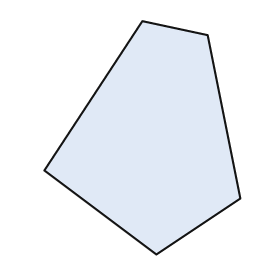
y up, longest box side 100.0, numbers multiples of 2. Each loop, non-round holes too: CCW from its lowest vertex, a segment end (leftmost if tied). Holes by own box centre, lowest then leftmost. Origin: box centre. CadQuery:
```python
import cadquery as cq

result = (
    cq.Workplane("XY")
    .moveTo(6.0, -50.0)
    .lineTo(42.0, -26.0)
    .lineTo(28.0, 44.0)
    .lineTo(0.0, 50.0)
    .lineTo(-42.0, -14.0)
    .close()
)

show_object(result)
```